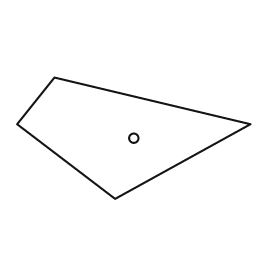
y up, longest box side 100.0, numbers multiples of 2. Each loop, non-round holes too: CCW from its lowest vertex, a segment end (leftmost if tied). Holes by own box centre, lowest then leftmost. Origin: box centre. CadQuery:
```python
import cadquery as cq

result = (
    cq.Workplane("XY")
    .moveTo(-8.0, -26.0)
    .lineTo(50.0, 6.0)
    .lineTo(-34.0, 26.0)
    .lineTo(-50.0, 6.0)
    .close()
    .moveTo(0.0, 0.0)
    .circle(2.0)
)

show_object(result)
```